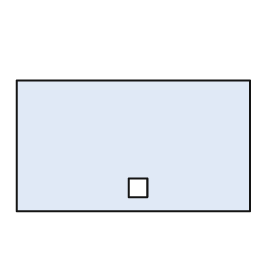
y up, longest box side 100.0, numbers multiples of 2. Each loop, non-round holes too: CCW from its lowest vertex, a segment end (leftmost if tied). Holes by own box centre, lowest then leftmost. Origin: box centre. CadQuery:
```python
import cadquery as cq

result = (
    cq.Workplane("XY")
    .moveTo(-50.0, -28.0)
    .lineTo(50.0, -28.0)
    .lineTo(50.0, 28.0)
    .lineTo(-50.0, 28.0)
    .close()
    .moveTo(-2.0, -22.0)
    .lineTo(6.0, -22.0)
    .lineTo(6.0, -14.0)
    .lineTo(-2.0, -14.0)
    .close()
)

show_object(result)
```